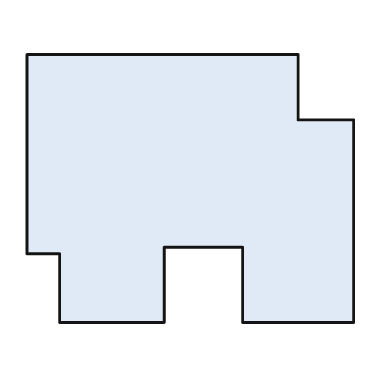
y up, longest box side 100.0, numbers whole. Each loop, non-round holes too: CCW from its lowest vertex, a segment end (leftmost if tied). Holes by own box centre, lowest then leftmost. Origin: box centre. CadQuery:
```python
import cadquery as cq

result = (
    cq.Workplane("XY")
    .moveTo(-40.0, -41.0)
    .lineTo(-8.0, -41.0)
    .lineTo(-8.0, -18.0)
    .lineTo(16.0, -18.0)
    .lineTo(16.0, -41.0)
    .lineTo(50.0, -41.0)
    .lineTo(50.0, 21.0)
    .lineTo(33.0, 21.0)
    .lineTo(33.0, 41.0)
    .lineTo(-50.0, 41.0)
    .lineTo(-50.0, -20.0)
    .lineTo(-40.0, -20.0)
    .close()
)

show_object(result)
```